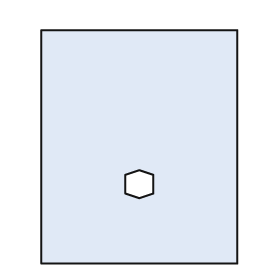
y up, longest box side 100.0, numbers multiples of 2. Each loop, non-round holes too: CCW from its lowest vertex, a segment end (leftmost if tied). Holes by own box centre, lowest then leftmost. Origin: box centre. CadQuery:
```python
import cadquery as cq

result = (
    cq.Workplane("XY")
    .moveTo(-42.0, -50.0)
    .lineTo(42.0, -50.0)
    .lineTo(42.0, 50.0)
    .lineTo(-42.0, 50.0)
    .close()
    .moveTo(0.0, -22.0)
    .lineTo(6.0, -20.0)
    .lineTo(6.0, -12.0)
    .lineTo(0.0, -10.0)
    .lineTo(-6.0, -12.0)
    .lineTo(-6.0, -20.0)
    .close()
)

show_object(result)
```